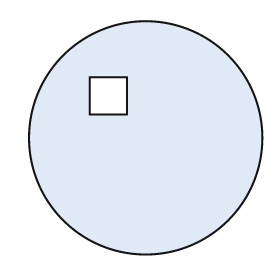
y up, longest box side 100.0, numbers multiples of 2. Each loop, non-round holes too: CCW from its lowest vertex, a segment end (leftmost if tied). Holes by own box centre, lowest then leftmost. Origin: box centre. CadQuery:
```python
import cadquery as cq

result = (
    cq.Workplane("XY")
    .moveTo(0.0, 0.0)
    .circle(50.0)
    .moveTo(-24.0, 10.0)
    .lineTo(-8.0, 10.0)
    .lineTo(-8.0, 26.0)
    .lineTo(-24.0, 26.0)
    .close()
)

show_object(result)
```